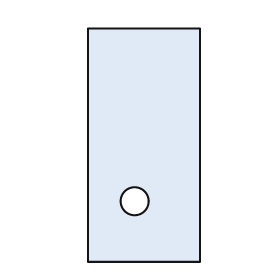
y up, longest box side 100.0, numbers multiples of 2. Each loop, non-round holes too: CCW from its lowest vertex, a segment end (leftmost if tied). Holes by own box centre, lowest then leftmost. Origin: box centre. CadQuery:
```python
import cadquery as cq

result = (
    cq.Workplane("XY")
    .moveTo(-24.0, -50.0)
    .lineTo(24.0, -50.0)
    .lineTo(24.0, 50.0)
    .lineTo(-24.0, 50.0)
    .close()
    .moveTo(-4.0, -24.0)
    .circle(6.0)
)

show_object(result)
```